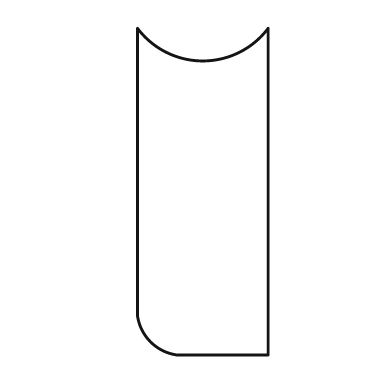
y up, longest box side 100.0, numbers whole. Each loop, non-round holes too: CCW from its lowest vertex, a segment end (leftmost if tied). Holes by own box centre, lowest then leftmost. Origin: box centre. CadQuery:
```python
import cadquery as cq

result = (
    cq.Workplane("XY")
    .moveTo(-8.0, -50.0)
    .lineTo(20.0, -50.0)
    .lineTo(20.0, 50.0)
    .threePointArc((0.0, 40.0), (-20.0, 50.0))
    .lineTo(-20.0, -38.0)
    .threePointArc((-16.0, -46.0), (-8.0, -50.0))
    .close()
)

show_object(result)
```